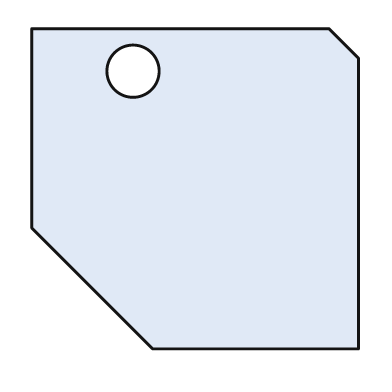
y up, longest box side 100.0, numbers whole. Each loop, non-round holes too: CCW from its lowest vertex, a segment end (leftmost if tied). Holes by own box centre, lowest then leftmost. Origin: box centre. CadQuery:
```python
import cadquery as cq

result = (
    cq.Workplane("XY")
    .moveTo(-13.0, -49.0)
    .lineTo(50.0, -49.0)
    .lineTo(50.0, 40.0)
    .lineTo(41.0, 49.0)
    .lineTo(-50.0, 49.0)
    .lineTo(-50.0, -12.0)
    .close()
    .moveTo(-19.0, 36.0)
    .circle(8.0)
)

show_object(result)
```